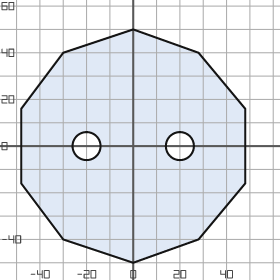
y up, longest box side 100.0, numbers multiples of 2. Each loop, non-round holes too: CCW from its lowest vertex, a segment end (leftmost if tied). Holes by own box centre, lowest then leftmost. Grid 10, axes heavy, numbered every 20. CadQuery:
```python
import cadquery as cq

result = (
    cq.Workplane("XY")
    .moveTo(0.0, -50.0)
    .lineTo(28.0, -40.0)
    .lineTo(48.0, -16.0)
    .lineTo(48.0, 16.0)
    .lineTo(28.0, 40.0)
    .lineTo(0.0, 50.0)
    .lineTo(-30.0, 40.0)
    .lineTo(-48.0, 16.0)
    .lineTo(-48.0, -16.0)
    .lineTo(-30.0, -40.0)
    .close()
    .moveTo(-20.0, 0.0)
    .circle(6.0)
    .moveTo(20.0, 0.0)
    .circle(6.0)
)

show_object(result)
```